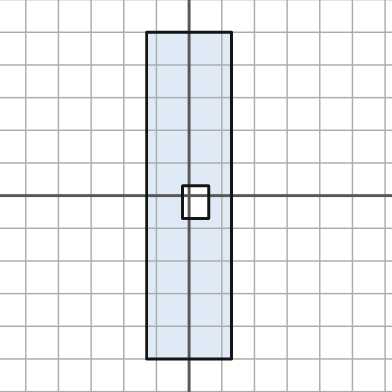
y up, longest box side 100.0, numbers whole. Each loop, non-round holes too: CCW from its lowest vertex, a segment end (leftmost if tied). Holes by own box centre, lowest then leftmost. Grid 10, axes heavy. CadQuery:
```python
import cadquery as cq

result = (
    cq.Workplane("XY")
    .moveTo(-13.0, -50.0)
    .lineTo(13.0, -50.0)
    .lineTo(13.0, 50.0)
    .lineTo(-13.0, 50.0)
    .close()
    .moveTo(-2.0, -7.0)
    .lineTo(6.0, -7.0)
    .lineTo(6.0, 3.0)
    .lineTo(-2.0, 3.0)
    .close()
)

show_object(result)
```